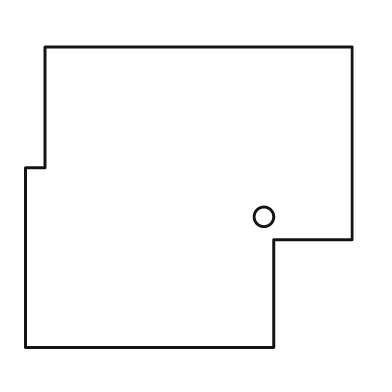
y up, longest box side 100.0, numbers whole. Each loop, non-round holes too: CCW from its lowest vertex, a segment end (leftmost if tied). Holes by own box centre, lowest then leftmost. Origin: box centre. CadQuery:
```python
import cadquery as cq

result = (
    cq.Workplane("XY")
    .moveTo(-50.0, -46.0)
    .lineTo(26.0, -46.0)
    .lineTo(26.0, -13.0)
    .lineTo(50.0, -13.0)
    .lineTo(50.0, 46.0)
    .lineTo(-44.0, 46.0)
    .lineTo(-44.0, 9.0)
    .lineTo(-50.0, 9.0)
    .close()
    .moveTo(23.0, -6.0)
    .circle(3.0)
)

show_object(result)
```